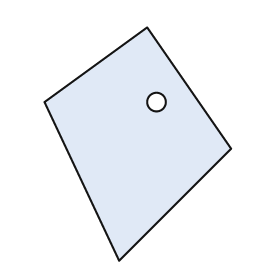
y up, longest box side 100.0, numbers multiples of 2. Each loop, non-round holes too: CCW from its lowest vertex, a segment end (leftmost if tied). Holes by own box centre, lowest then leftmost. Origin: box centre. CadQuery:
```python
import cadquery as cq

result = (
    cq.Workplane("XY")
    .moveTo(-8.0, -50.0)
    .lineTo(40.0, -2.0)
    .lineTo(4.0, 50.0)
    .lineTo(-40.0, 18.0)
    .close()
    .moveTo(8.0, 18.0)
    .circle(4.0)
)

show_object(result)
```